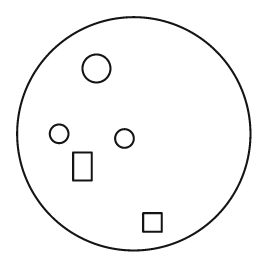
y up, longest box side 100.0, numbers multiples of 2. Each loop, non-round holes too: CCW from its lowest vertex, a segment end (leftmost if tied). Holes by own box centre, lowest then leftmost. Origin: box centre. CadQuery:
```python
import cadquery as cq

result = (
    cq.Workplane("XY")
    .moveTo(0.0, 0.0)
    .circle(50.0)
    .moveTo(4.0, -42.0)
    .lineTo(12.0, -42.0)
    .lineTo(12.0, -34.0)
    .lineTo(4.0, -34.0)
    .close()
    .moveTo(-26.0, -20.0)
    .lineTo(-18.0, -20.0)
    .lineTo(-18.0, -8.0)
    .lineTo(-26.0, -8.0)
    .close()
    .moveTo(-4.0, -2.0)
    .circle(4.0)
    .moveTo(-32.0, 0.0)
    .circle(4.0)
    .moveTo(-16.0, 28.0)
    .circle(6.0)
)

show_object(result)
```